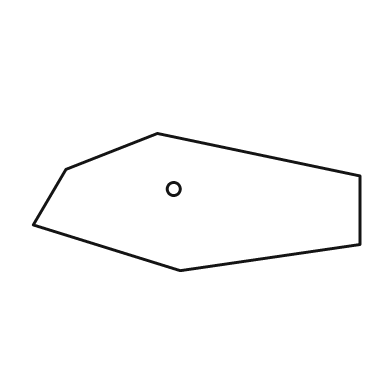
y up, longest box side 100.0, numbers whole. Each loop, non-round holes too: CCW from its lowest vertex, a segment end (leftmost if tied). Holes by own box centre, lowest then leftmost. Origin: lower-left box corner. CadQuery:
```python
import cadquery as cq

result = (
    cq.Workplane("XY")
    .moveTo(45.0, 0.0)
    .lineTo(100.0, 8.0)
    .lineTo(100.0, 29.0)
    .lineTo(38.0, 42.0)
    .lineTo(10.0, 31.0)
    .lineTo(0.0, 14.0)
    .close()
    .moveTo(43.0, 25.0)
    .circle(2.0)
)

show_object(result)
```